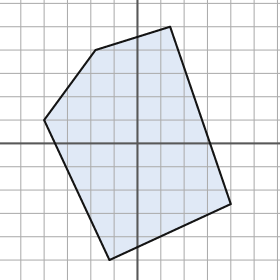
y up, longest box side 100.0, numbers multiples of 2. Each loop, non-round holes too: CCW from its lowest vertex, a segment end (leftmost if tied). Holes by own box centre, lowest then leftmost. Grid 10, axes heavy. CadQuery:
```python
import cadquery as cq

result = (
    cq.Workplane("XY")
    .moveTo(-12.0, -50.0)
    .lineTo(40.0, -26.0)
    .lineTo(14.0, 50.0)
    .lineTo(-18.0, 40.0)
    .lineTo(-40.0, 10.0)
    .close()
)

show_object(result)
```